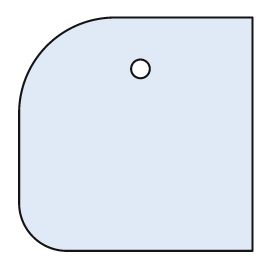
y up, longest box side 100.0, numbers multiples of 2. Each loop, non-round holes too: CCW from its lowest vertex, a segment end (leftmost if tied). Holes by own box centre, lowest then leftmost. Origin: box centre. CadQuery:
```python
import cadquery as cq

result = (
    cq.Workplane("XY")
    .moveTo(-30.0, -50.0)
    .lineTo(50.0, -50.0)
    .lineTo(50.0, 50.0)
    .lineTo(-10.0, 50.0)
    .threePointArc((-38.0, 38.0), (-50.0, 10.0))
    .lineTo(-50.0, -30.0)
    .threePointArc((-44.0, -44.0), (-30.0, -50.0))
    .close()
    .moveTo(2.0, 28.0)
    .circle(4.0)
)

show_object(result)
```